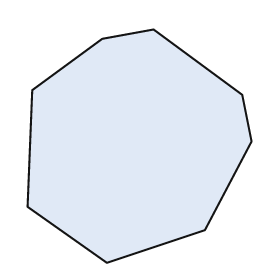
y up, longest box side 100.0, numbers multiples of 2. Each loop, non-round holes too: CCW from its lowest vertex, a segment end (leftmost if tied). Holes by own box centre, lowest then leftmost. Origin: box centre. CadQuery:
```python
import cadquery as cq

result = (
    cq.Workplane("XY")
    .moveTo(-14.0, -50.0)
    .lineTo(28.0, -36.0)
    .lineTo(48.0, 2.0)
    .lineTo(44.0, 22.0)
    .lineTo(6.0, 50.0)
    .lineTo(-16.0, 46.0)
    .lineTo(-46.0, 24.0)
    .lineTo(-48.0, -26.0)
    .close()
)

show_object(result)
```